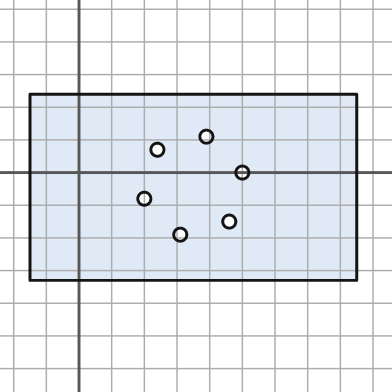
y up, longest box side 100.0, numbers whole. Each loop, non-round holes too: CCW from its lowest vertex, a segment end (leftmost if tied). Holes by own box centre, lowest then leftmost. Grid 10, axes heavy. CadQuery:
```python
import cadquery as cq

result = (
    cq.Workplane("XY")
    .moveTo(-15.0, -33.0)
    .lineTo(85.0, -33.0)
    .lineTo(85.0, 24.0)
    .lineTo(-15.0, 24.0)
    .close()
    .moveTo(31.0, -19.0)
    .circle(2.0)
    .moveTo(46.0, -15.0)
    .circle(2.0)
    .moveTo(20.0, -8.0)
    .circle(2.0)
    .moveTo(50.0, 0.0)
    .circle(2.0)
    .moveTo(24.0, 7.0)
    .circle(2.0)
    .moveTo(39.0, 11.0)
    .circle(2.0)
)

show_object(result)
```